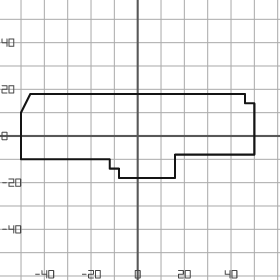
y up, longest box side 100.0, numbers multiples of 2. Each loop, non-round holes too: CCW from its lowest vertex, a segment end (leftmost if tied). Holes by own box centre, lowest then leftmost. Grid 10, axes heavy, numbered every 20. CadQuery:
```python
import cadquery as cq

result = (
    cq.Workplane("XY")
    .moveTo(-8.0, -18.0)
    .lineTo(16.0, -18.0)
    .lineTo(16.0, -8.0)
    .lineTo(50.0, -8.0)
    .lineTo(50.0, 14.0)
    .lineTo(46.0, 14.0)
    .lineTo(46.0, 18.0)
    .lineTo(-46.0, 18.0)
    .lineTo(-50.0, 10.0)
    .lineTo(-50.0, -10.0)
    .lineTo(-12.0, -10.0)
    .lineTo(-12.0, -14.0)
    .lineTo(-8.0, -14.0)
    .close()
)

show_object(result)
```